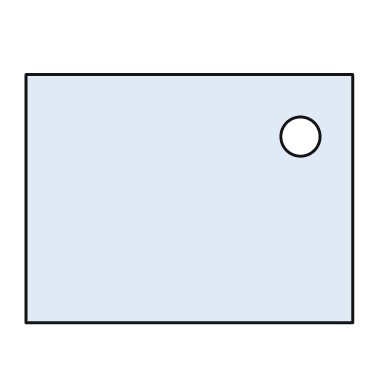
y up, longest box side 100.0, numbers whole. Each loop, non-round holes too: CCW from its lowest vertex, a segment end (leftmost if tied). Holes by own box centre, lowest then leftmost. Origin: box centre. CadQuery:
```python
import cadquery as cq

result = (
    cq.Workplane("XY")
    .moveTo(-50.0, -38.0)
    .lineTo(50.0, -38.0)
    .lineTo(50.0, 38.0)
    .lineTo(-50.0, 38.0)
    .close()
    .moveTo(34.0, 19.0)
    .circle(6.0)
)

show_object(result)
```